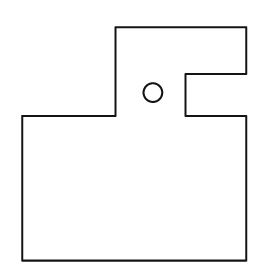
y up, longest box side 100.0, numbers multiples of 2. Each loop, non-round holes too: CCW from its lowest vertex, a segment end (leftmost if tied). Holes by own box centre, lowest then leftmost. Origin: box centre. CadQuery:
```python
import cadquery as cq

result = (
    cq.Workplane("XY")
    .moveTo(-48.0, -50.0)
    .lineTo(48.0, -50.0)
    .lineTo(48.0, 12.0)
    .lineTo(22.0, 12.0)
    .lineTo(22.0, 30.0)
    .lineTo(48.0, 30.0)
    .lineTo(48.0, 50.0)
    .lineTo(-8.0, 50.0)
    .lineTo(-8.0, 12.0)
    .lineTo(-48.0, 12.0)
    .close()
    .moveTo(8.0, 22.0)
    .circle(4.0)
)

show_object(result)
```